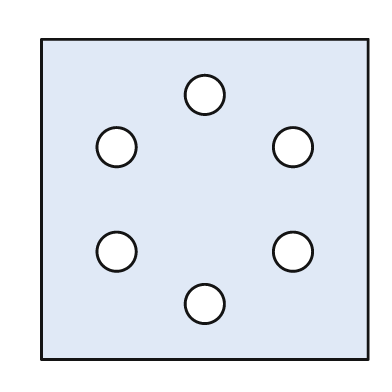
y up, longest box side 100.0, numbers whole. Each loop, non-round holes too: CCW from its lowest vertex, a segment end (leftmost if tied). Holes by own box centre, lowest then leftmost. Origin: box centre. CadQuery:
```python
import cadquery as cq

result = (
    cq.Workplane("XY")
    .moveTo(-50.0, -49.0)
    .lineTo(50.0, -49.0)
    .lineTo(50.0, 49.0)
    .lineTo(-50.0, 49.0)
    .close()
    .moveTo(0.0, -32.0)
    .circle(6.0)
    .moveTo(-27.0, -16.0)
    .circle(6.0)
    .moveTo(27.0, -16.0)
    .circle(6.0)
    .moveTo(-27.0, 16.0)
    .circle(6.0)
    .moveTo(27.0, 16.0)
    .circle(6.0)
    .moveTo(0.0, 32.0)
    .circle(6.0)
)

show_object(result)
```